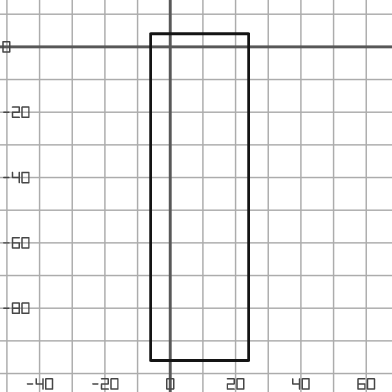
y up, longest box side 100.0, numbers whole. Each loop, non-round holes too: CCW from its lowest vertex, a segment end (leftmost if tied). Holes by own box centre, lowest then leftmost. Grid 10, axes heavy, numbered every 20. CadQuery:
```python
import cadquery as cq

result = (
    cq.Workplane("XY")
    .moveTo(-6.0, -96.0)
    .lineTo(24.0, -96.0)
    .lineTo(24.0, 4.0)
    .lineTo(-6.0, 4.0)
    .close()
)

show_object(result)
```